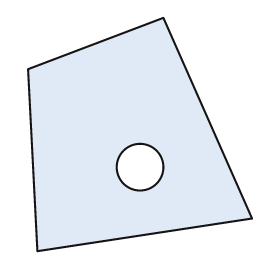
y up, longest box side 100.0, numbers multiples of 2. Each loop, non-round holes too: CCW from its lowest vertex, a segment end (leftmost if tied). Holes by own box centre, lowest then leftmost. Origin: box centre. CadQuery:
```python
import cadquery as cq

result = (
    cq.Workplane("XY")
    .moveTo(-44.0, -50.0)
    .lineTo(48.0, -36.0)
    .lineTo(10.0, 50.0)
    .lineTo(-48.0, 28.0)
    .close()
    .moveTo(0.0, -14.0)
    .circle(10.0)
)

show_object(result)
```